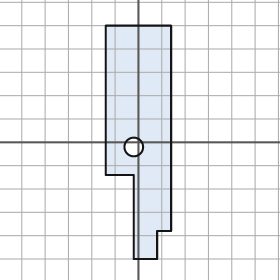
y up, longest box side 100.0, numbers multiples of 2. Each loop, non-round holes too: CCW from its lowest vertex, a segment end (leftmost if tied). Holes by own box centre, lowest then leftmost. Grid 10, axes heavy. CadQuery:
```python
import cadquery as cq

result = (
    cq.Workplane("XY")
    .moveTo(-2.0, -50.0)
    .lineTo(8.0, -50.0)
    .lineTo(8.0, -38.0)
    .lineTo(14.0, -38.0)
    .lineTo(14.0, 50.0)
    .lineTo(-14.0, 50.0)
    .lineTo(-14.0, -14.0)
    .lineTo(-2.0, -14.0)
    .close()
    .moveTo(-2.0, -2.0)
    .circle(4.0)
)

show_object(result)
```